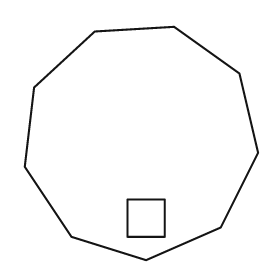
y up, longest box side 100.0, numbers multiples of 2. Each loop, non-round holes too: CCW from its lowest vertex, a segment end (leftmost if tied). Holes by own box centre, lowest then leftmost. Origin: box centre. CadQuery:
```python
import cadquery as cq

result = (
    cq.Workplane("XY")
    .moveTo(2.0, -50.0)
    .lineTo(34.0, -36.0)
    .lineTo(50.0, -4.0)
    .lineTo(42.0, 30.0)
    .lineTo(14.0, 50.0)
    .lineTo(-20.0, 48.0)
    .lineTo(-46.0, 24.0)
    .lineTo(-50.0, -10.0)
    .lineTo(-30.0, -40.0)
    .close()
    .moveTo(-6.0, -40.0)
    .lineTo(10.0, -40.0)
    .lineTo(10.0, -24.0)
    .lineTo(-6.0, -24.0)
    .close()
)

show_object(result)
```